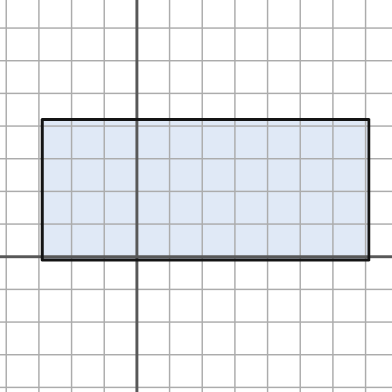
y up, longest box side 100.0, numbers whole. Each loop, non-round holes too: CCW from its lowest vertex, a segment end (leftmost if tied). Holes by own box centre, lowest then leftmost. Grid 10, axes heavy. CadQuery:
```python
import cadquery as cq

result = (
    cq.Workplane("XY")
    .moveTo(-29.0, -1.0)
    .lineTo(71.0, -1.0)
    .lineTo(71.0, 42.0)
    .lineTo(-29.0, 42.0)
    .close()
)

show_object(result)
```